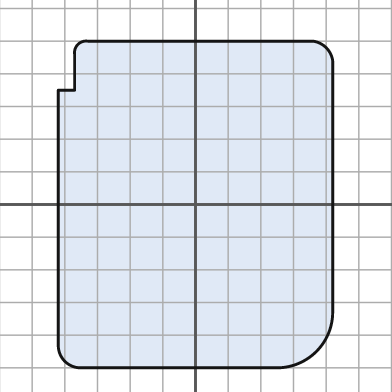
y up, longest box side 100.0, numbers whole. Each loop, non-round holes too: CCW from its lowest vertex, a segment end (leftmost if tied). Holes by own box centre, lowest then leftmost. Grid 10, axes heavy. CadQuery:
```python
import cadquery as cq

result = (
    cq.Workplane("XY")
    .moveTo(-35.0, -50.0)
    .lineTo(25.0, -50.0)
    .threePointArc((37.0, -45.0), (42.0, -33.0))
    .lineTo(42.0, 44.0)
    .threePointArc((40.0, 48.0), (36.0, 50.0))
    .lineTo(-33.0, 50.0)
    .threePointArc((-36.0, 49.0), (-37.0, 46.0))
    .lineTo(-37.0, 35.0)
    .lineTo(-42.0, 35.0)
    .lineTo(-42.0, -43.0)
    .threePointArc((-40.0, -48.0), (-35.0, -50.0))
    .close()
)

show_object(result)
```